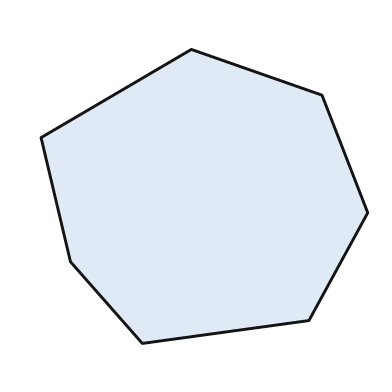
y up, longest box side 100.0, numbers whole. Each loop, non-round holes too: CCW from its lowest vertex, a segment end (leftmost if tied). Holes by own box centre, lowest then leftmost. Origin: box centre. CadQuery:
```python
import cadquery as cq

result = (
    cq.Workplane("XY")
    .moveTo(-19.0, -45.0)
    .lineTo(32.0, -38.0)
    .lineTo(50.0, -5.0)
    .lineTo(36.0, 31.0)
    .lineTo(-4.0, 45.0)
    .lineTo(-50.0, 18.0)
    .lineTo(-41.0, -20.0)
    .close()
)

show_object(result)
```